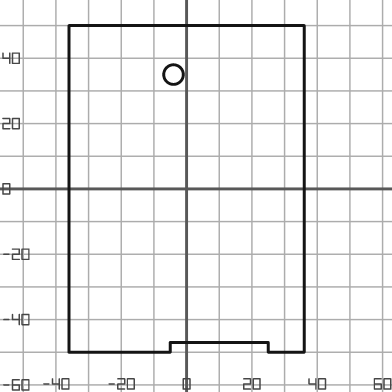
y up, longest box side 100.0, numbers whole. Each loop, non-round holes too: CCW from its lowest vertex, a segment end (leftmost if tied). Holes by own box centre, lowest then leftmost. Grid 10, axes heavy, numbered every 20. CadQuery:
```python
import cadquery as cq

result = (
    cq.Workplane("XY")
    .moveTo(-36.0, -50.0)
    .lineTo(-5.0, -50.0)
    .lineTo(-5.0, -47.0)
    .lineTo(25.0, -47.0)
    .lineTo(25.0, -50.0)
    .lineTo(36.0, -50.0)
    .lineTo(36.0, 50.0)
    .lineTo(-36.0, 50.0)
    .close()
    .moveTo(-4.0, 35.0)
    .circle(3.0)
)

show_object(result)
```